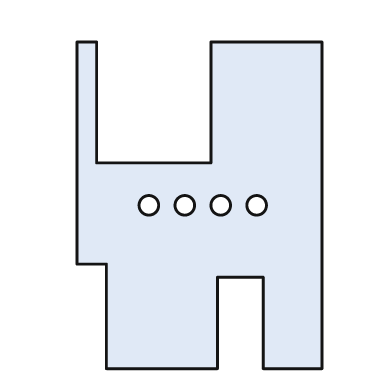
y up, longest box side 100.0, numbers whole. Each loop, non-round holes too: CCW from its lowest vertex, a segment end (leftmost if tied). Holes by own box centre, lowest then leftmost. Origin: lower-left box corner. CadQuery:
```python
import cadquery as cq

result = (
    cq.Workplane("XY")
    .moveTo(9.0, 0.0)
    .lineTo(43.0, 0.0)
    .lineTo(43.0, 28.0)
    .lineTo(57.0, 28.0)
    .lineTo(57.0, 0.0)
    .lineTo(75.0, 0.0)
    .lineTo(75.0, 100.0)
    .lineTo(41.0, 100.0)
    .lineTo(41.0, 63.0)
    .lineTo(6.0, 63.0)
    .lineTo(6.0, 100.0)
    .lineTo(0.0, 100.0)
    .lineTo(0.0, 32.0)
    .lineTo(9.0, 32.0)
    .close()
    .moveTo(22.0, 50.0)
    .circle(3.0)
    .moveTo(33.0, 50.0)
    .circle(3.0)
    .moveTo(44.0, 50.0)
    .circle(3.0)
    .moveTo(55.0, 50.0)
    .circle(3.0)
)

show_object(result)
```